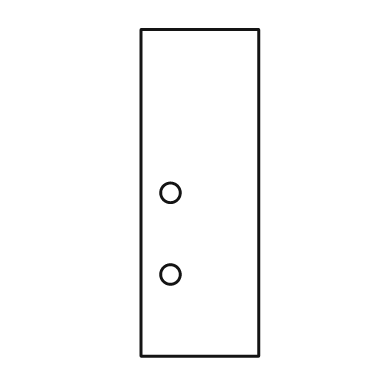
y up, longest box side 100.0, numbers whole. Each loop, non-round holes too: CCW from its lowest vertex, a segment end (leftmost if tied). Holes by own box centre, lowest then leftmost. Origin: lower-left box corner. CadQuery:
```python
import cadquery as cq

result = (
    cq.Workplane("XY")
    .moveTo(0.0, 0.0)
    .lineTo(36.0, 0.0)
    .lineTo(36.0, 100.0)
    .lineTo(0.0, 100.0)
    .close()
    .moveTo(9.0, 25.0)
    .circle(3.0)
    .moveTo(9.0, 50.0)
    .circle(3.0)
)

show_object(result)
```